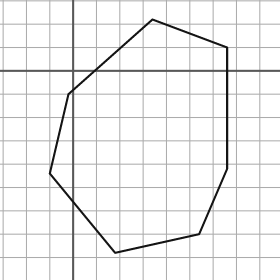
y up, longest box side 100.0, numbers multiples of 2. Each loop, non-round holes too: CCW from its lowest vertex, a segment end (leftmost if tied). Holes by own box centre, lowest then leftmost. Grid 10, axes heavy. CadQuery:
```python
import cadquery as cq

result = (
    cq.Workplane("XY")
    .moveTo(18.0, -78.0)
    .lineTo(54.0, -70.0)
    .lineTo(66.0, -42.0)
    .lineTo(66.0, 10.0)
    .lineTo(34.0, 22.0)
    .lineTo(-2.0, -10.0)
    .lineTo(-10.0, -44.0)
    .close()
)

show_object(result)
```